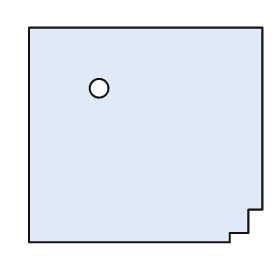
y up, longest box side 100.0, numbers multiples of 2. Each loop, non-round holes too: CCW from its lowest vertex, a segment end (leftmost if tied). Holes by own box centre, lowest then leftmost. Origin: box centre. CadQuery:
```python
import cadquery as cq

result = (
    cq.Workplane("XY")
    .moveTo(-50.0, -46.0)
    .lineTo(36.0, -46.0)
    .lineTo(36.0, -42.0)
    .lineTo(44.0, -42.0)
    .lineTo(44.0, -32.0)
    .lineTo(50.0, -32.0)
    .lineTo(50.0, 46.0)
    .lineTo(-50.0, 46.0)
    .close()
    .moveTo(-20.0, 20.0)
    .circle(4.0)
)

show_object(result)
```